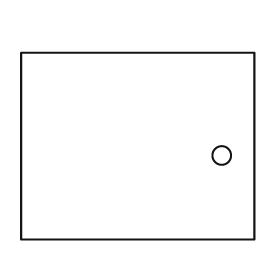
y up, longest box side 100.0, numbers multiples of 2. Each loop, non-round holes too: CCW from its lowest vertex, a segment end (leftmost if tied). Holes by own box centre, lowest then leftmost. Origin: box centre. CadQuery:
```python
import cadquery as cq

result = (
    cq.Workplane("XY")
    .moveTo(-50.0, -40.0)
    .lineTo(50.0, -40.0)
    .lineTo(50.0, 40.0)
    .lineTo(-50.0, 40.0)
    .close()
    .moveTo(36.0, -4.0)
    .circle(4.0)
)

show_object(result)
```